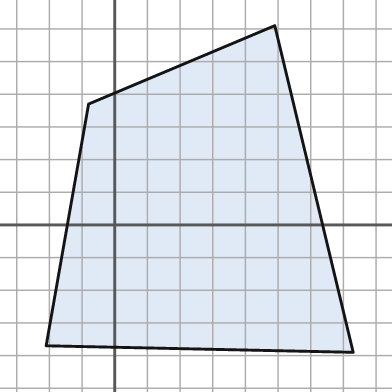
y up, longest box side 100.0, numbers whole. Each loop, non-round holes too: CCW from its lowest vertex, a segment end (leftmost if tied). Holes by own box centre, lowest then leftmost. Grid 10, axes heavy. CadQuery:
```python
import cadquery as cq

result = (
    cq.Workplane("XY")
    .moveTo(73.0, -39.0)
    .lineTo(49.0, 61.0)
    .lineTo(-8.0, 37.0)
    .lineTo(-21.0, -37.0)
    .close()
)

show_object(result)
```